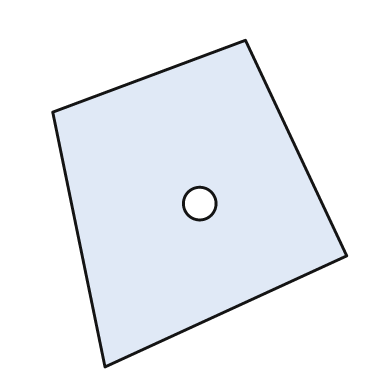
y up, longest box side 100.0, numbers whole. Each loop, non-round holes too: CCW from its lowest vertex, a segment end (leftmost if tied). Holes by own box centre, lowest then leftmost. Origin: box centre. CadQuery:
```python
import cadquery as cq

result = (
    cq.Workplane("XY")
    .moveTo(-29.0, -50.0)
    .lineTo(45.0, -16.0)
    .lineTo(14.0, 50.0)
    .lineTo(-45.0, 28.0)
    .close()
    .moveTo(0.0, 0.0)
    .circle(5.0)
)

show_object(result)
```